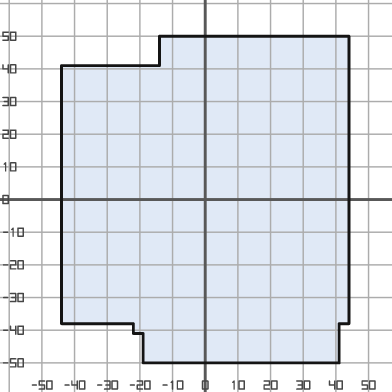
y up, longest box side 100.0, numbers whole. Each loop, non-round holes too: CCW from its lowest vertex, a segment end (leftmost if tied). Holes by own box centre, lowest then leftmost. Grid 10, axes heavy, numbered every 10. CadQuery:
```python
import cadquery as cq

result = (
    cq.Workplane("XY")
    .moveTo(-19.0, -50.0)
    .lineTo(41.0, -50.0)
    .lineTo(41.0, -38.0)
    .lineTo(44.0, -38.0)
    .lineTo(44.0, 50.0)
    .lineTo(-14.0, 50.0)
    .lineTo(-14.0, 41.0)
    .lineTo(-44.0, 41.0)
    .lineTo(-44.0, -38.0)
    .lineTo(-22.0, -38.0)
    .lineTo(-22.0, -41.0)
    .lineTo(-19.0, -41.0)
    .close()
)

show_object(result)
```